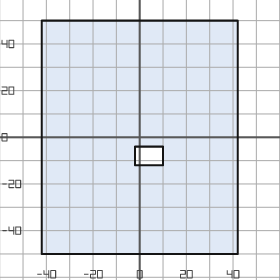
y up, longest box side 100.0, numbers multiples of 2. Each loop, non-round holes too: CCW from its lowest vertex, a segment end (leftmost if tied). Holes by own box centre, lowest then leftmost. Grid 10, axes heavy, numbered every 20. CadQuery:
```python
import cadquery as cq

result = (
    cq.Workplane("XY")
    .moveTo(-42.0, -50.0)
    .lineTo(42.0, -50.0)
    .lineTo(42.0, 50.0)
    .lineTo(-42.0, 50.0)
    .close()
    .moveTo(-2.0, -12.0)
    .lineTo(10.0, -12.0)
    .lineTo(10.0, -4.0)
    .lineTo(-2.0, -4.0)
    .close()
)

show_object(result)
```